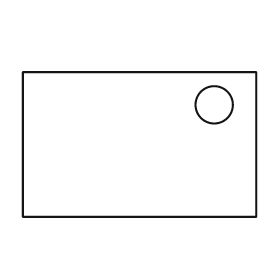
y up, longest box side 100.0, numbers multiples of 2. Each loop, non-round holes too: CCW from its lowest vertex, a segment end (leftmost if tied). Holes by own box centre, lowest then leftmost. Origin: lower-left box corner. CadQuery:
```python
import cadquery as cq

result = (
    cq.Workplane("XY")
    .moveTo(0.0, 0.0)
    .lineTo(100.0, 0.0)
    .lineTo(100.0, 62.0)
    .lineTo(0.0, 62.0)
    .close()
    .moveTo(82.0, 48.0)
    .circle(8.0)
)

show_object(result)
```